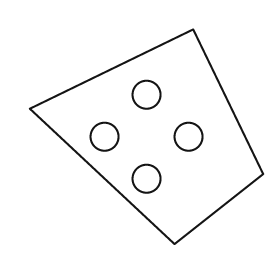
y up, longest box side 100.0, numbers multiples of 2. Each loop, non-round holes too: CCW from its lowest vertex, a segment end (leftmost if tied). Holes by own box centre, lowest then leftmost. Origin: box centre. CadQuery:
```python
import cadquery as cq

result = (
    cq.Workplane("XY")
    .moveTo(12.0, -46.0)
    .lineTo(50.0, -16.0)
    .lineTo(20.0, 46.0)
    .lineTo(-50.0, 12.0)
    .close()
    .moveTo(0.0, -18.0)
    .circle(6.0)
    .moveTo(-18.0, 0.0)
    .circle(6.0)
    .moveTo(18.0, 0.0)
    .circle(6.0)
    .moveTo(0.0, 18.0)
    .circle(6.0)
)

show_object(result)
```